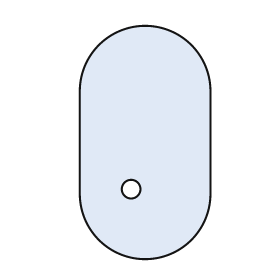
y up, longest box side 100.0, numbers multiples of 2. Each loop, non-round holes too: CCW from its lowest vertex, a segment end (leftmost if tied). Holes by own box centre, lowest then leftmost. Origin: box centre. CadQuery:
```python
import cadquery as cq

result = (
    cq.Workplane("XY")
    .moveTo(-28.0, -22.0)
    .threePointArc((0.0, -50.0), (28.0, -22.0))
    .lineTo(28.0, 22.0)
    .threePointArc((0.0, 50.0), (-28.0, 22.0))
    .close()
    .moveTo(-6.0, -20.0)
    .circle(4.0)
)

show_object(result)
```